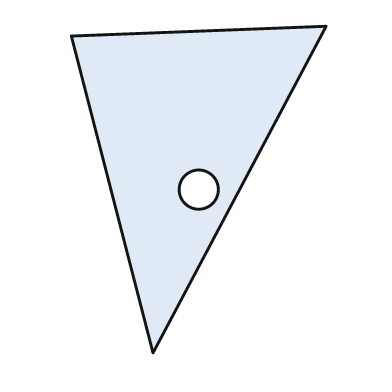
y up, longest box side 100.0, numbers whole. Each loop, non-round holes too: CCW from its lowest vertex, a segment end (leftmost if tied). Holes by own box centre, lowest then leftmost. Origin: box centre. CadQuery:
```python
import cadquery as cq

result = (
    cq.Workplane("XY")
    .moveTo(-14.0, -50.0)
    .lineTo(39.0, 50.0)
    .lineTo(-39.0, 47.0)
    .close()
    .moveTo(0.0, 0.0)
    .circle(6.0)
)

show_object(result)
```